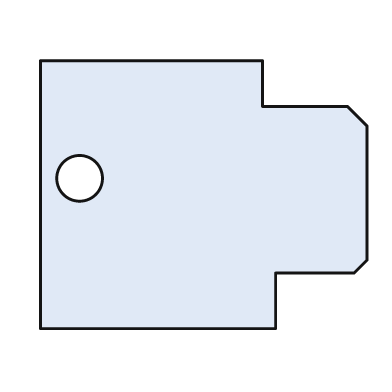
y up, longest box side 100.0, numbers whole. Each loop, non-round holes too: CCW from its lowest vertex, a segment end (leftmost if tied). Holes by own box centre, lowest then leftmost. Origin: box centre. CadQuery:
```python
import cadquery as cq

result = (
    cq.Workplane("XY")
    .moveTo(-50.0, -41.0)
    .lineTo(22.0, -41.0)
    .lineTo(22.0, -24.0)
    .lineTo(46.0, -24.0)
    .lineTo(50.0, -20.0)
    .lineTo(50.0, 21.0)
    .lineTo(44.0, 27.0)
    .lineTo(18.0, 27.0)
    .lineTo(18.0, 41.0)
    .lineTo(-50.0, 41.0)
    .close()
    .moveTo(-38.0, 5.0)
    .circle(7.0)
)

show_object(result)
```